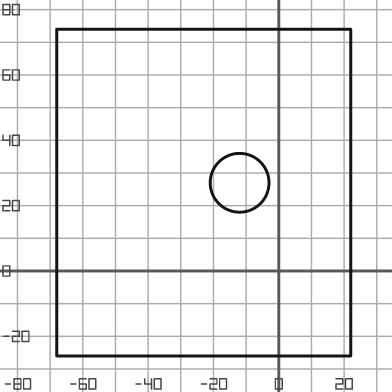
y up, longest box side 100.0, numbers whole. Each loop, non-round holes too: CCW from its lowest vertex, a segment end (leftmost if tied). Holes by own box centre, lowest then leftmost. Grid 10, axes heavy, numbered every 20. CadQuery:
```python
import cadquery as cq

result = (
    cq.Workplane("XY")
    .moveTo(-68.0, -26.0)
    .lineTo(22.0, -26.0)
    .lineTo(22.0, 74.0)
    .lineTo(-68.0, 74.0)
    .close()
    .moveTo(-12.0, 27.0)
    .circle(9.0)
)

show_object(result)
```